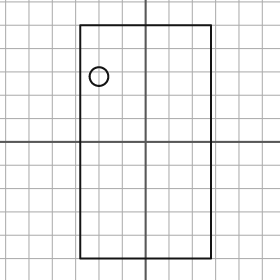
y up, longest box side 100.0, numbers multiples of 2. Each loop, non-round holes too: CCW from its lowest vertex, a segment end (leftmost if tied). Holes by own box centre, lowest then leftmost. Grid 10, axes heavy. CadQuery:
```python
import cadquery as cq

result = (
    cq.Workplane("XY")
    .moveTo(-28.0, -50.0)
    .lineTo(28.0, -50.0)
    .lineTo(28.0, 50.0)
    .lineTo(-28.0, 50.0)
    .close()
    .moveTo(-20.0, 28.0)
    .circle(4.0)
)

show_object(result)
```